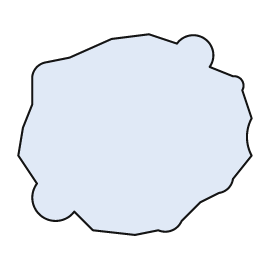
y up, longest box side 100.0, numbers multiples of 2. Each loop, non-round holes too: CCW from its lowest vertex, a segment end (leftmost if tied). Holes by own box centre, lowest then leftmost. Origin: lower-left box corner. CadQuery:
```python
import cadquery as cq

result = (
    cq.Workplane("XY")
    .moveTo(50.0, 0.0)
    .lineTo(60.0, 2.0)
    .threePointArc((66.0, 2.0), (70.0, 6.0))
    .lineTo(78.0, 14.0)
    .lineTo(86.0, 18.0)
    .threePointArc((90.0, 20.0), (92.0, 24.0))
    .lineTo(100.0, 34.0)
    .threePointArc((98.0, 42.0), (100.0, 50.0))
    .lineTo(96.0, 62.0)
    .threePointArc((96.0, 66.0), (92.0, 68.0))
    .lineTo(82.0, 72.0)
    .threePointArc((80.0, 84.0), (68.0, 82.0))
    .lineTo(56.0, 86.0)
    .lineTo(40.0, 84.0)
    .lineTo(22.0, 76.0)
    .lineTo(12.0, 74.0)
    .threePointArc((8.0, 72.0), (6.0, 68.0))
    .lineTo(6.0, 56.0)
    .lineTo(2.0, 46.0)
    .lineTo(0.0, 34.0)
    .lineTo(8.0, 22.0)
    .threePointArc((10.0, 8.0), (24.0, 10.0))
    .lineTo(32.0, 2.0)
    .close()
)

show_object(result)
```